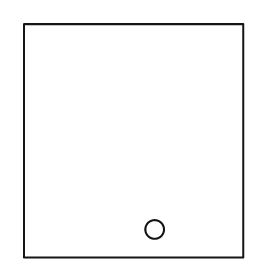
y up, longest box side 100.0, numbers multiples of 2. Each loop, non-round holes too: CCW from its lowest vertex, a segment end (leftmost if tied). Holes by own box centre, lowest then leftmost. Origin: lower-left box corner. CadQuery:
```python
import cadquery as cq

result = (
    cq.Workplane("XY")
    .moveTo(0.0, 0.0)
    .lineTo(94.0, 0.0)
    .lineTo(94.0, 100.0)
    .lineTo(0.0, 100.0)
    .close()
    .moveTo(56.0, 12.0)
    .circle(4.0)
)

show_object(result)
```